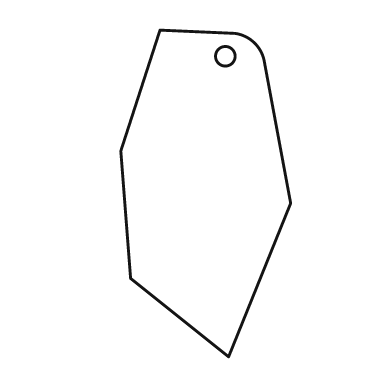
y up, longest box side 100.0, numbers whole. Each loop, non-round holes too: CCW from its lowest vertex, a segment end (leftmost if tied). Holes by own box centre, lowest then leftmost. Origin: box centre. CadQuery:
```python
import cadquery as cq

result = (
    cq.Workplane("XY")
    .moveTo(7.0, -50.0)
    .lineTo(26.0, -3.0)
    .lineTo(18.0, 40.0)
    .threePointArc((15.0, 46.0), (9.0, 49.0))
    .lineTo(-14.0, 50.0)
    .lineTo(-26.0, 13.0)
    .lineTo(-23.0, -26.0)
    .close()
    .moveTo(6.0, 42.0)
    .circle(3.0)
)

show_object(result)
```